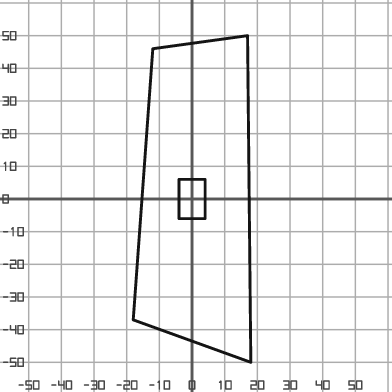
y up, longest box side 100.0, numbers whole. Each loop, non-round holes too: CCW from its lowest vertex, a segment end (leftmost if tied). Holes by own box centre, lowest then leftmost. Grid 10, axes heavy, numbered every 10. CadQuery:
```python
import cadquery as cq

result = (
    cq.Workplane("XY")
    .moveTo(18.0, -50.0)
    .lineTo(17.0, 50.0)
    .lineTo(-12.0, 46.0)
    .lineTo(-18.0, -37.0)
    .close()
    .moveTo(-4.0, -6.0)
    .lineTo(4.0, -6.0)
    .lineTo(4.0, 6.0)
    .lineTo(-4.0, 6.0)
    .close()
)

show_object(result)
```